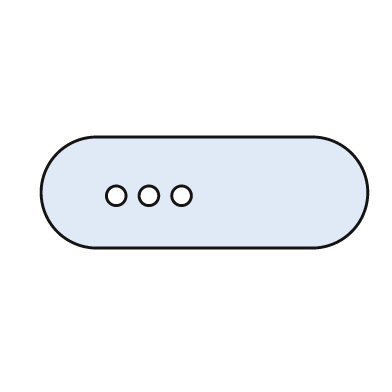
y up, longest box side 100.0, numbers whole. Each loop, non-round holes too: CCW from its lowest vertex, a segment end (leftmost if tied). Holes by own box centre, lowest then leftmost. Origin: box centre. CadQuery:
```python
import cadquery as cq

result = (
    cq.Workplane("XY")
    .moveTo(-33.0, -17.0)
    .lineTo(33.0, -17.0)
    .threePointArc((50.0, 0.0), (33.0, 17.0))
    .lineTo(-33.0, 17.0)
    .threePointArc((-50.0, 0.0), (-33.0, -17.0))
    .close()
    .moveTo(-27.0, -1.0)
    .circle(3.0)
    .moveTo(-17.0, -1.0)
    .circle(3.0)
    .moveTo(-7.0, -1.0)
    .circle(3.0)
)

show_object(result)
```